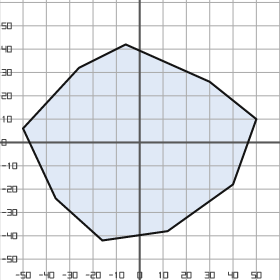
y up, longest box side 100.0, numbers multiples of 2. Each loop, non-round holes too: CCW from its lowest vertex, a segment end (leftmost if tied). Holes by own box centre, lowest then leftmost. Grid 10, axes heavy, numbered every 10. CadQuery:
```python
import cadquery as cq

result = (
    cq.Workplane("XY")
    .moveTo(-16.0, -42.0)
    .lineTo(12.0, -38.0)
    .lineTo(40.0, -18.0)
    .lineTo(50.0, 10.0)
    .lineTo(30.0, 26.0)
    .lineTo(-6.0, 42.0)
    .lineTo(-26.0, 32.0)
    .lineTo(-50.0, 6.0)
    .lineTo(-36.0, -24.0)
    .close()
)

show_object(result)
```